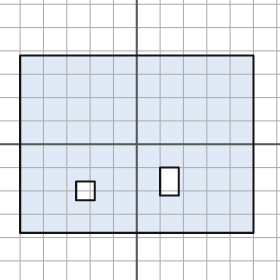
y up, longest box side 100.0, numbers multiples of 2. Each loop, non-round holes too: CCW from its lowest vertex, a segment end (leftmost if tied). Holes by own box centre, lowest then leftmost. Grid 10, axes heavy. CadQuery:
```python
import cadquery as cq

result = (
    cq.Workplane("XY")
    .moveTo(-50.0, -38.0)
    .lineTo(50.0, -38.0)
    .lineTo(50.0, 38.0)
    .lineTo(-50.0, 38.0)
    .close()
    .moveTo(-26.0, -24.0)
    .lineTo(-18.0, -24.0)
    .lineTo(-18.0, -16.0)
    .lineTo(-26.0, -16.0)
    .close()
    .moveTo(10.0, -22.0)
    .lineTo(18.0, -22.0)
    .lineTo(18.0, -10.0)
    .lineTo(10.0, -10.0)
    .close()
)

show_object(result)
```